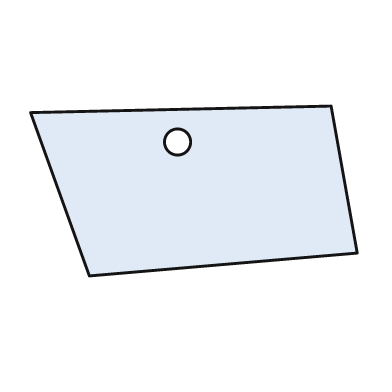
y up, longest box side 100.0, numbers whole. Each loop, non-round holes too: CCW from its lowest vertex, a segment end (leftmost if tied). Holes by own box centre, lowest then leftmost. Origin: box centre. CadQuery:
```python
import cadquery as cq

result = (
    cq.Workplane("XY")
    .moveTo(-32.0, -26.0)
    .lineTo(50.0, -19.0)
    .lineTo(42.0, 26.0)
    .lineTo(-50.0, 24.0)
    .close()
    .moveTo(-5.0, 15.0)
    .circle(4.0)
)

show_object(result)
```